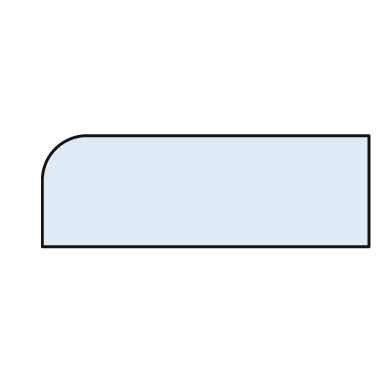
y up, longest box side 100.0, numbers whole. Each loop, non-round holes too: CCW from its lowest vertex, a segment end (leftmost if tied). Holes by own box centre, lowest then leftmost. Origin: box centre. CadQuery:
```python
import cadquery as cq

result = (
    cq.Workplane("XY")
    .moveTo(-50.0, -17.0)
    .lineTo(50.0, -17.0)
    .lineTo(50.0, 17.0)
    .lineTo(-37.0, 17.0)
    .threePointArc((-46.0, 13.0), (-50.0, 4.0))
    .close()
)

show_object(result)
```